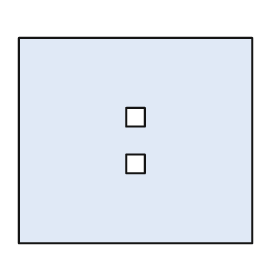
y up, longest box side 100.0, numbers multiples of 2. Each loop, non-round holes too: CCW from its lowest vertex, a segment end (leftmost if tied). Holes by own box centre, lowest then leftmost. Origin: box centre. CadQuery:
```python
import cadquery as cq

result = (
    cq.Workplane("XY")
    .moveTo(-50.0, -44.0)
    .lineTo(50.0, -44.0)
    .lineTo(50.0, 44.0)
    .lineTo(-50.0, 44.0)
    .close()
    .moveTo(-4.0, -14.0)
    .lineTo(4.0, -14.0)
    .lineTo(4.0, -6.0)
    .lineTo(-4.0, -6.0)
    .close()
    .moveTo(-4.0, 6.0)
    .lineTo(4.0, 6.0)
    .lineTo(4.0, 14.0)
    .lineTo(-4.0, 14.0)
    .close()
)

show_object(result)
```